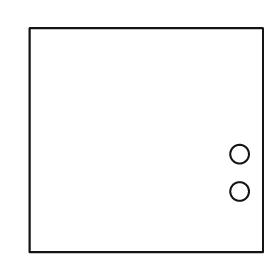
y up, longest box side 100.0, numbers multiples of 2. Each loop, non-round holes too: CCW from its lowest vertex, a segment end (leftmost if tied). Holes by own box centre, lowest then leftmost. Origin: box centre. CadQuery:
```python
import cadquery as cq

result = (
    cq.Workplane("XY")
    .moveTo(-50.0, -48.0)
    .lineTo(50.0, -48.0)
    .lineTo(50.0, 48.0)
    .lineTo(-50.0, 48.0)
    .close()
    .moveTo(40.0, -22.0)
    .circle(4.0)
    .moveTo(40.0, -6.0)
    .circle(4.0)
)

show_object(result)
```